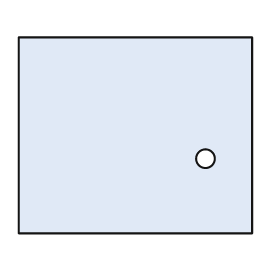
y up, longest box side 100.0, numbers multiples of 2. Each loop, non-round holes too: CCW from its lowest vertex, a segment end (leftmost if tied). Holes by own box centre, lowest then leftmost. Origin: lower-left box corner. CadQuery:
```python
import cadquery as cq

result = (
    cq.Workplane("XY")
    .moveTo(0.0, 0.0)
    .lineTo(100.0, 0.0)
    .lineTo(100.0, 84.0)
    .lineTo(0.0, 84.0)
    .close()
    .moveTo(80.0, 32.0)
    .circle(4.0)
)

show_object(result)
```